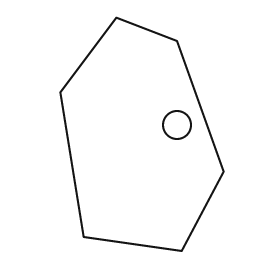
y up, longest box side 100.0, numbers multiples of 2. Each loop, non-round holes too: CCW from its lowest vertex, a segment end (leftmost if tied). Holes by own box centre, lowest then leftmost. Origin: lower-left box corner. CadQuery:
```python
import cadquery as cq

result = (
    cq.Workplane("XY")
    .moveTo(52.0, 0.0)
    .lineTo(70.0, 34.0)
    .lineTo(50.0, 90.0)
    .lineTo(24.0, 100.0)
    .lineTo(0.0, 68.0)
    .lineTo(10.0, 6.0)
    .close()
    .moveTo(50.0, 54.0)
    .circle(6.0)
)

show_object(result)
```